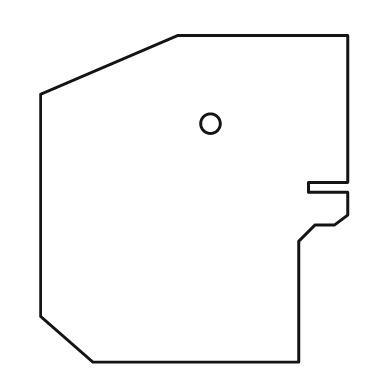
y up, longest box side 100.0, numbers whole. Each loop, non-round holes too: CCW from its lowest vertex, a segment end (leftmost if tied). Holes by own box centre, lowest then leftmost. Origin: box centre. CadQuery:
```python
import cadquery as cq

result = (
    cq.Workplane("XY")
    .moveTo(-31.0, -50.0)
    .lineTo(32.0, -50.0)
    .lineTo(32.0, -13.0)
    .lineTo(37.0, -8.0)
    .lineTo(43.0, -8.0)
    .lineTo(47.0, -5.0)
    .lineTo(47.0, 2.0)
    .lineTo(35.0, 2.0)
    .lineTo(35.0, 5.0)
    .lineTo(47.0, 5.0)
    .lineTo(47.0, 50.0)
    .lineTo(-5.0, 50.0)
    .lineTo(-47.0, 32.0)
    .lineTo(-47.0, -36.0)
    .close()
    .moveTo(5.0, 23.0)
    .circle(3.0)
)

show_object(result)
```